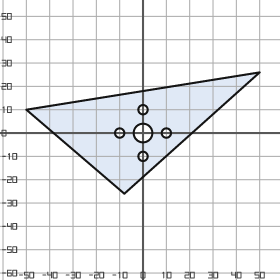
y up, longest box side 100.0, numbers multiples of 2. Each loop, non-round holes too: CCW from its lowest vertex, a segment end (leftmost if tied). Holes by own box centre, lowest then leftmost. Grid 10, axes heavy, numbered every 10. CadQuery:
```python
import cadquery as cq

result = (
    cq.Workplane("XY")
    .moveTo(-8.0, -26.0)
    .lineTo(50.0, 26.0)
    .lineTo(-50.0, 10.0)
    .close()
    .moveTo(0.0, -10.0)
    .circle(2.0)
    .moveTo(-10.0, 0.0)
    .circle(2.0)
    .moveTo(0.0, 0.0)
    .circle(4.0)
    .moveTo(10.0, 0.0)
    .circle(2.0)
    .moveTo(0.0, 10.0)
    .circle(2.0)
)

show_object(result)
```